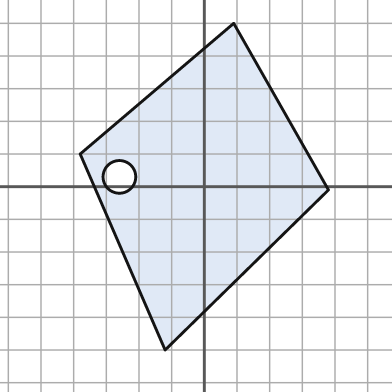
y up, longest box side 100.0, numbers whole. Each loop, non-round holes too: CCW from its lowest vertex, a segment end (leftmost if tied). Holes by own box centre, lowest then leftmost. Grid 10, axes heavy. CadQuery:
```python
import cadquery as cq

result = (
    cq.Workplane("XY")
    .moveTo(-12.0, -50.0)
    .lineTo(38.0, -1.0)
    .lineTo(9.0, 50.0)
    .lineTo(-38.0, 10.0)
    .close()
    .moveTo(-26.0, 3.0)
    .circle(5.0)
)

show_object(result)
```